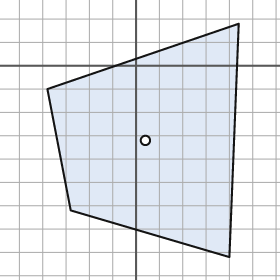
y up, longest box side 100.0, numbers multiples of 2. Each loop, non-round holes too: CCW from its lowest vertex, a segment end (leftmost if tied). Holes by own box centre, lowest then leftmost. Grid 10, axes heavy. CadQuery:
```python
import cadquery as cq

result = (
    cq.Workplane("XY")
    .moveTo(40.0, -82.0)
    .lineTo(44.0, 18.0)
    .lineTo(-38.0, -10.0)
    .lineTo(-28.0, -62.0)
    .close()
    .moveTo(4.0, -32.0)
    .circle(2.0)
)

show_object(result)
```